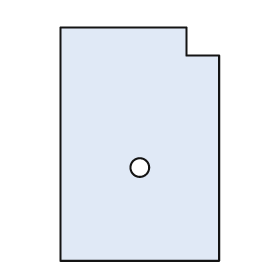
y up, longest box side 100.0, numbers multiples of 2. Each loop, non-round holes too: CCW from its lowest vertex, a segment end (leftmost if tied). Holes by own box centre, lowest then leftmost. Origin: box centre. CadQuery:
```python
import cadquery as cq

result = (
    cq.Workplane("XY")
    .moveTo(-34.0, -50.0)
    .lineTo(34.0, -50.0)
    .lineTo(34.0, 38.0)
    .lineTo(20.0, 38.0)
    .lineTo(20.0, 50.0)
    .lineTo(-34.0, 50.0)
    .close()
    .moveTo(0.0, -10.0)
    .circle(4.0)
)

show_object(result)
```